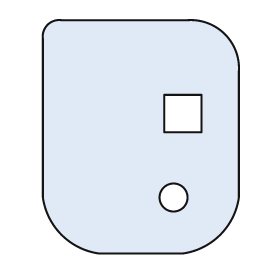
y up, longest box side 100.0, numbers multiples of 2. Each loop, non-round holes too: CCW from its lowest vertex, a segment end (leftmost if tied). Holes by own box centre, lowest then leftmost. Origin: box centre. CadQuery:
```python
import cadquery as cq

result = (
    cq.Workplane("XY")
    .moveTo(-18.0, -50.0)
    .lineTo(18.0, -50.0)
    .threePointArc((34.0, -42.0), (42.0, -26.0))
    .lineTo(42.0, 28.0)
    .threePointArc((36.0, 44.0), (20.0, 50.0))
    .lineTo(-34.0, 50.0)
    .threePointArc((-40.0, 48.0), (-42.0, 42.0))
    .lineTo(-42.0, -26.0)
    .threePointArc((-34.0, -42.0), (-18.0, -50.0))
    .close()
    .moveTo(14.0, -26.0)
    .circle(6.0)
    .moveTo(10.0, 2.0)
    .lineTo(26.0, 2.0)
    .lineTo(26.0, 18.0)
    .lineTo(10.0, 18.0)
    .close()
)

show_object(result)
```